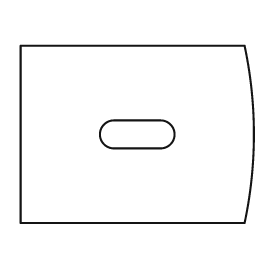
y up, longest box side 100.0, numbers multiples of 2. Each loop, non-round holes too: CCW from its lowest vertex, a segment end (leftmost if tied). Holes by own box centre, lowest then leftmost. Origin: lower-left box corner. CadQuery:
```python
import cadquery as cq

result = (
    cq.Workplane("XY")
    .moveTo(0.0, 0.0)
    .lineTo(96.0, 0.0)
    .threePointArc((100.0, 38.0), (96.0, 76.0))
    .lineTo(0.0, 76.0)
    .close()
    .moveTo(40.0, 32.0)
    .lineTo(60.0, 32.0)
    .threePointArc((66.0, 38.0), (60.0, 44.0))
    .lineTo(40.0, 44.0)
    .threePointArc((34.0, 38.0), (40.0, 32.0))
    .close()
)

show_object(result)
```